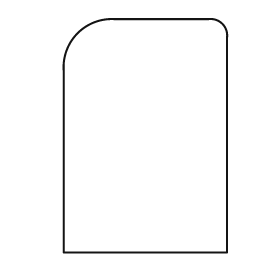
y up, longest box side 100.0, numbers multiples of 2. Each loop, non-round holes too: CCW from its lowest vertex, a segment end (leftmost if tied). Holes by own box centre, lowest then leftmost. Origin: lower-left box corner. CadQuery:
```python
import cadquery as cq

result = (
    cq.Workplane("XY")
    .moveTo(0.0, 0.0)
    .lineTo(70.0, 0.0)
    .lineTo(70.0, 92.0)
    .threePointArc((68.0, 98.0), (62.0, 100.0))
    .lineTo(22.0, 100.0)
    .threePointArc((6.0, 94.0), (0.0, 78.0))
    .close()
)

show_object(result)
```